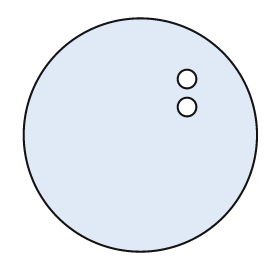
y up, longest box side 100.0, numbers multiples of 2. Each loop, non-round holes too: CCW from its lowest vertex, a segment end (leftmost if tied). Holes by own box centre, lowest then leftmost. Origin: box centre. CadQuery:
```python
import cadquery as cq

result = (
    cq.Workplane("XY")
    .moveTo(0.0, 0.0)
    .circle(50.0)
    .moveTo(20.0, 12.0)
    .circle(4.0)
    .moveTo(20.0, 24.0)
    .circle(4.0)
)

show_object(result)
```